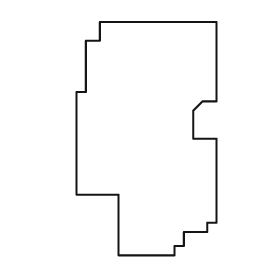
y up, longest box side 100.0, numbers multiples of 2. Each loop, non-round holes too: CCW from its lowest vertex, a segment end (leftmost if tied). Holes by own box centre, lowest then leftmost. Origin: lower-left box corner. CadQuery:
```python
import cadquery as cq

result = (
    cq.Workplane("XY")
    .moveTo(18.0, 0.0)
    .lineTo(42.0, 0.0)
    .lineTo(42.0, 4.0)
    .lineTo(46.0, 4.0)
    .lineTo(46.0, 10.0)
    .lineTo(56.0, 10.0)
    .lineTo(56.0, 14.0)
    .lineTo(60.0, 14.0)
    .lineTo(60.0, 50.0)
    .lineTo(50.0, 50.0)
    .lineTo(50.0, 62.0)
    .lineTo(54.0, 66.0)
    .lineTo(60.0, 66.0)
    .lineTo(60.0, 100.0)
    .lineTo(10.0, 100.0)
    .lineTo(10.0, 92.0)
    .lineTo(4.0, 92.0)
    .lineTo(4.0, 70.0)
    .lineTo(0.0, 70.0)
    .lineTo(0.0, 26.0)
    .lineTo(18.0, 26.0)
    .close()
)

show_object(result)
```